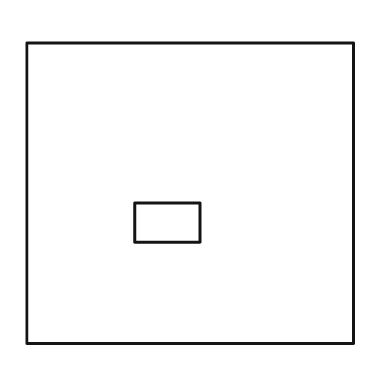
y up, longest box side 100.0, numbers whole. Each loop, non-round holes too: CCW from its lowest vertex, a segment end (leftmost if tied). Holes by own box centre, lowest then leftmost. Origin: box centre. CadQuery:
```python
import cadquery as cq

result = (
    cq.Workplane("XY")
    .moveTo(-50.0, -46.0)
    .lineTo(50.0, -46.0)
    .lineTo(50.0, 46.0)
    .lineTo(-50.0, 46.0)
    .close()
    .moveTo(-17.0, -15.0)
    .lineTo(3.0, -15.0)
    .lineTo(3.0, -3.0)
    .lineTo(-17.0, -3.0)
    .close()
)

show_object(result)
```